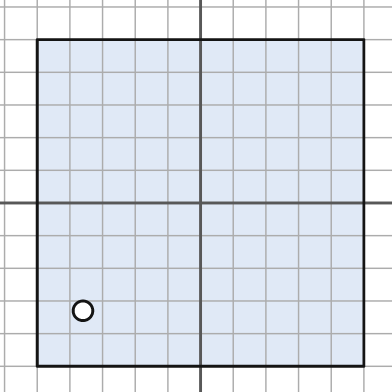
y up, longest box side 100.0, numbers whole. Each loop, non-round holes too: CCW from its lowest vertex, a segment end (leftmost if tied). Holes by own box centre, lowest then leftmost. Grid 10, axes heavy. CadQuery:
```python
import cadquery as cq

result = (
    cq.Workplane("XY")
    .moveTo(-50.0, -50.0)
    .lineTo(50.0, -50.0)
    .lineTo(50.0, 50.0)
    .lineTo(-50.0, 50.0)
    .close()
    .moveTo(-36.0, -33.0)
    .circle(3.0)
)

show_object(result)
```